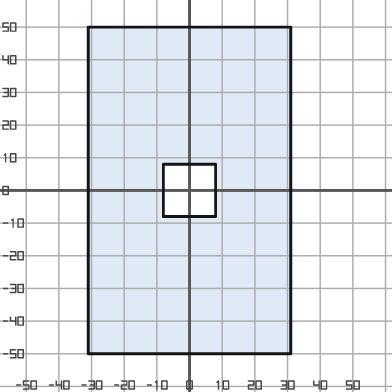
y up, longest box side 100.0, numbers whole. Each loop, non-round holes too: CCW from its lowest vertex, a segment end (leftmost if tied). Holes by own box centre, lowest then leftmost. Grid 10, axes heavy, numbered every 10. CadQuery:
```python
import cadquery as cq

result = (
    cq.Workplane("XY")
    .moveTo(-31.0, -50.0)
    .lineTo(31.0, -50.0)
    .lineTo(31.0, 50.0)
    .lineTo(-31.0, 50.0)
    .close()
    .moveTo(-8.0, -8.0)
    .lineTo(8.0, -8.0)
    .lineTo(8.0, 8.0)
    .lineTo(-8.0, 8.0)
    .close()
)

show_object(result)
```